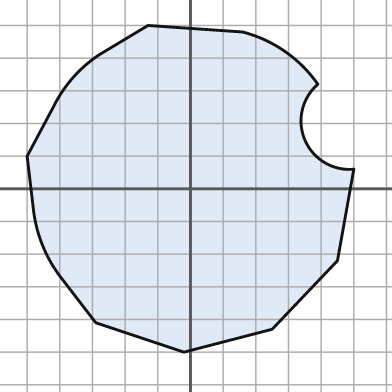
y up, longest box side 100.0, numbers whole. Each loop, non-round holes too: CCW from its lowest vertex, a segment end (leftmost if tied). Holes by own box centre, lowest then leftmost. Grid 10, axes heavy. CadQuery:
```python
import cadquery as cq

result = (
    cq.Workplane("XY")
    .moveTo(-2.0, -50.0)
    .lineTo(25.0, -43.0)
    .lineTo(45.0, -22.0)
    .lineTo(50.0, 6.0)
    .threePointArc((35.0, 15.0), (39.0, 32.0))
    .threePointArc((29.0, 42.0), (16.0, 48.0))
    .lineTo(-13.0, 50.0)
    .lineTo(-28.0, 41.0)
    .threePointArc((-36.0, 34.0), (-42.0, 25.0))
    .lineTo(-50.0, 10.0)
    .lineTo(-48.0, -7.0)
    .threePointArc((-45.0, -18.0), (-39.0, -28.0))
    .lineTo(-29.0, -41.0)
    .close()
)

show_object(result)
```